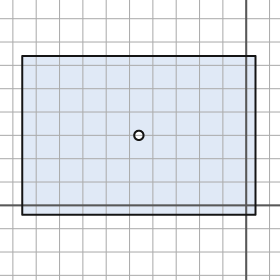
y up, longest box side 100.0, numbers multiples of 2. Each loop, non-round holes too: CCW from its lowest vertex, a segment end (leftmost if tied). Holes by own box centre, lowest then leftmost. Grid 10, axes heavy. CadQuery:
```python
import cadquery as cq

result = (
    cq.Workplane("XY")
    .moveTo(-96.0, -4.0)
    .lineTo(4.0, -4.0)
    .lineTo(4.0, 64.0)
    .lineTo(-96.0, 64.0)
    .close()
    .moveTo(-46.0, 30.0)
    .circle(2.0)
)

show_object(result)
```